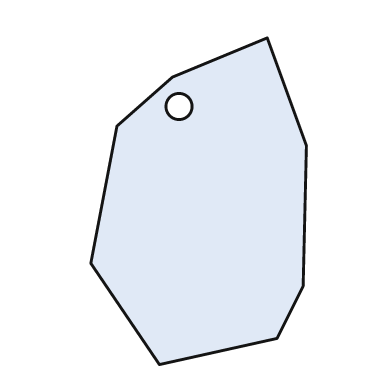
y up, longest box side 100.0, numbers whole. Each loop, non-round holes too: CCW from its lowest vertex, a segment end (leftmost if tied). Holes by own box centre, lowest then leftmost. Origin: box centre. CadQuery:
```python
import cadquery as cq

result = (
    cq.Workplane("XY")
    .moveTo(-12.0, -50.0)
    .lineTo(24.0, -42.0)
    .lineTo(32.0, -26.0)
    .lineTo(33.0, 17.0)
    .lineTo(21.0, 50.0)
    .lineTo(-8.0, 38.0)
    .lineTo(-25.0, 23.0)
    .lineTo(-33.0, -19.0)
    .close()
    .moveTo(-6.0, 29.0)
    .circle(4.0)
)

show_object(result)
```